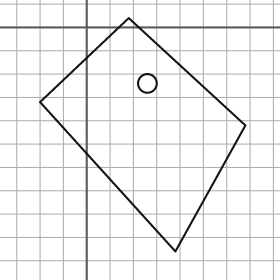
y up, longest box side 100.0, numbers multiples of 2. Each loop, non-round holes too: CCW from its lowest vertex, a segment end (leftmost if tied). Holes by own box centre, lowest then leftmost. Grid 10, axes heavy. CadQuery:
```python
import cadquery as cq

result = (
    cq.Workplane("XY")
    .moveTo(38.0, -96.0)
    .lineTo(68.0, -42.0)
    .lineTo(18.0, 4.0)
    .lineTo(-20.0, -32.0)
    .close()
    .moveTo(26.0, -24.0)
    .circle(4.0)
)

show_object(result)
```